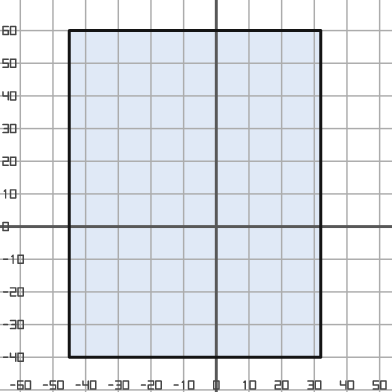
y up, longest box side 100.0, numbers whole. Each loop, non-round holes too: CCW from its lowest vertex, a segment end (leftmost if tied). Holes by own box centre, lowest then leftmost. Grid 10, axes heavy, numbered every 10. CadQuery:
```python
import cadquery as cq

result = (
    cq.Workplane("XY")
    .moveTo(-45.0, -40.0)
    .lineTo(32.0, -40.0)
    .lineTo(32.0, 60.0)
    .lineTo(-45.0, 60.0)
    .close()
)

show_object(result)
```